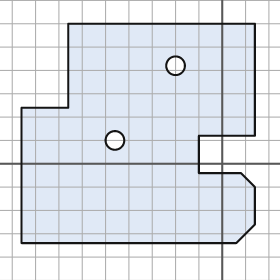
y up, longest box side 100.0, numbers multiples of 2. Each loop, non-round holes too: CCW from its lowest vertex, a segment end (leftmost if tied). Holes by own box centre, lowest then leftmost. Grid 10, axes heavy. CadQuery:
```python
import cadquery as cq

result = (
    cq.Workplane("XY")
    .moveTo(-86.0, -34.0)
    .lineTo(6.0, -34.0)
    .lineTo(14.0, -26.0)
    .lineTo(14.0, -10.0)
    .lineTo(8.0, -4.0)
    .lineTo(-10.0, -4.0)
    .lineTo(-10.0, 12.0)
    .lineTo(14.0, 12.0)
    .lineTo(14.0, 60.0)
    .lineTo(-66.0, 60.0)
    .lineTo(-66.0, 24.0)
    .lineTo(-86.0, 24.0)
    .close()
    .moveTo(-46.0, 10.0)
    .circle(4.0)
    .moveTo(-20.0, 42.0)
    .circle(4.0)
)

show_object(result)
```